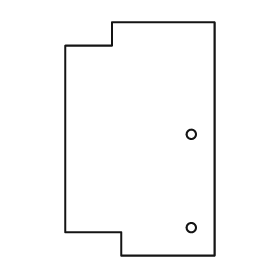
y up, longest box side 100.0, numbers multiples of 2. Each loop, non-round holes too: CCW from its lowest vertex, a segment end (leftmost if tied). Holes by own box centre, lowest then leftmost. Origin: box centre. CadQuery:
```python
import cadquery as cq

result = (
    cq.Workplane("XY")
    .moveTo(-8.0, -50.0)
    .lineTo(32.0, -50.0)
    .lineTo(32.0, 50.0)
    .lineTo(-12.0, 50.0)
    .lineTo(-12.0, 40.0)
    .lineTo(-32.0, 40.0)
    .lineTo(-32.0, -40.0)
    .lineTo(-8.0, -40.0)
    .close()
    .moveTo(22.0, -38.0)
    .circle(2.0)
    .moveTo(22.0, 2.0)
    .circle(2.0)
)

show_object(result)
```